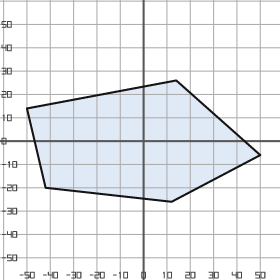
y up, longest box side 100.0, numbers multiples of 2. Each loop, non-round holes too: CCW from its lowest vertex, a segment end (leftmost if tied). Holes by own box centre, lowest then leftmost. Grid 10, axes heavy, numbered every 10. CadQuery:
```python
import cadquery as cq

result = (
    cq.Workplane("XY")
    .moveTo(12.0, -26.0)
    .lineTo(50.0, -6.0)
    .lineTo(14.0, 26.0)
    .lineTo(-50.0, 14.0)
    .lineTo(-42.0, -20.0)
    .close()
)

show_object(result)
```